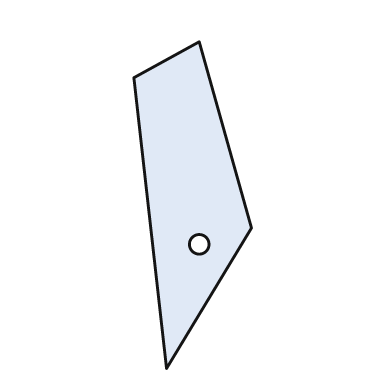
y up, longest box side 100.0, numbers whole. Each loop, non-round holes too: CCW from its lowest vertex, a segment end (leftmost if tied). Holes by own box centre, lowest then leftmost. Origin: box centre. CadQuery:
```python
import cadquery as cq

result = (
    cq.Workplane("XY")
    .moveTo(-8.0, -50.0)
    .lineTo(18.0, -7.0)
    .lineTo(2.0, 50.0)
    .lineTo(-18.0, 39.0)
    .close()
    .moveTo(2.0, -12.0)
    .circle(3.0)
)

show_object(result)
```